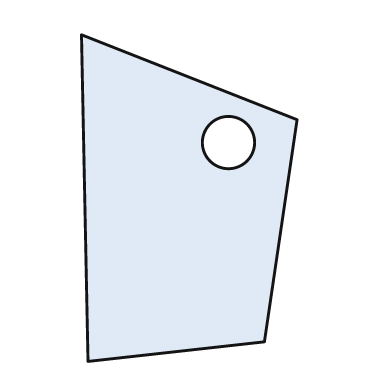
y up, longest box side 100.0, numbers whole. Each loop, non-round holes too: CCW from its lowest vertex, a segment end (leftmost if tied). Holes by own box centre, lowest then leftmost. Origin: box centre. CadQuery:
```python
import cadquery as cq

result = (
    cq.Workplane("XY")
    .moveTo(-31.0, -50.0)
    .lineTo(23.0, -44.0)
    .lineTo(33.0, 24.0)
    .lineTo(-33.0, 50.0)
    .close()
    .moveTo(12.0, 17.0)
    .circle(8.0)
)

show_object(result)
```